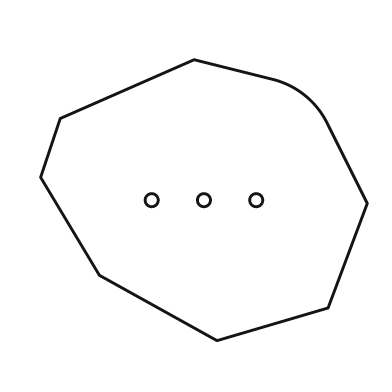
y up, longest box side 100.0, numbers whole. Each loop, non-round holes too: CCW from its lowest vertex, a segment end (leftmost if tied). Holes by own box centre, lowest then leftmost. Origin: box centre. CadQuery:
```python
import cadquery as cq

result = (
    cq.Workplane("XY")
    .moveTo(4.0, -43.0)
    .lineTo(38.0, -33.0)
    .lineTo(50.0, -1.0)
    .lineTo(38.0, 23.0)
    .threePointArc((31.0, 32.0), (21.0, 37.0))
    .lineTo(-3.0, 43.0)
    .lineTo(-44.0, 25.0)
    .lineTo(-50.0, 7.0)
    .lineTo(-32.0, -23.0)
    .close()
    .moveTo(-16.0, 0.0)
    .circle(2.0)
    .moveTo(0.0, 0.0)
    .circle(2.0)
    .moveTo(16.0, 0.0)
    .circle(2.0)
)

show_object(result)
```